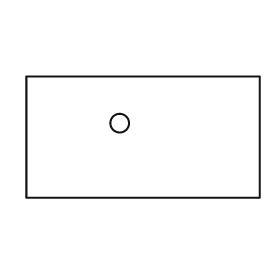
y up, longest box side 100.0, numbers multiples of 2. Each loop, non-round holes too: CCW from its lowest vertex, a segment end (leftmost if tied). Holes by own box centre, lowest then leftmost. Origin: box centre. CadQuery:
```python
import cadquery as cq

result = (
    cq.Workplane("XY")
    .moveTo(-50.0, -26.0)
    .lineTo(50.0, -26.0)
    .lineTo(50.0, 26.0)
    .lineTo(-50.0, 26.0)
    .close()
    .moveTo(-10.0, 6.0)
    .circle(4.0)
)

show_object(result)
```